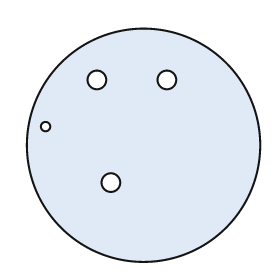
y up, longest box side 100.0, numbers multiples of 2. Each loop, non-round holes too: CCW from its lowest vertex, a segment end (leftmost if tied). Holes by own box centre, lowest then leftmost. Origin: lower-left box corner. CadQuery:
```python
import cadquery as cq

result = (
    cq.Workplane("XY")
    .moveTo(50.0, 50.0)
    .circle(50.0)
    .moveTo(36.0, 34.0)
    .circle(4.0)
    .moveTo(8.0, 58.0)
    .circle(2.0)
    .moveTo(30.0, 78.0)
    .circle(4.0)
    .moveTo(60.0, 78.0)
    .circle(4.0)
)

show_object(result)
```